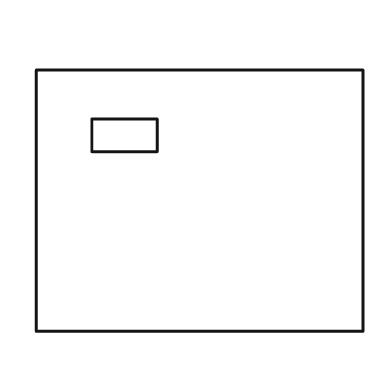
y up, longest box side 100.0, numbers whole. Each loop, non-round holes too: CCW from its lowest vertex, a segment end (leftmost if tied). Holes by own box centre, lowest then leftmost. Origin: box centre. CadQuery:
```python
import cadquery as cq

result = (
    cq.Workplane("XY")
    .moveTo(-50.0, -40.0)
    .lineTo(50.0, -40.0)
    .lineTo(50.0, 40.0)
    .lineTo(-50.0, 40.0)
    .close()
    .moveTo(-33.0, 15.0)
    .lineTo(-13.0, 15.0)
    .lineTo(-13.0, 25.0)
    .lineTo(-33.0, 25.0)
    .close()
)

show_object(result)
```